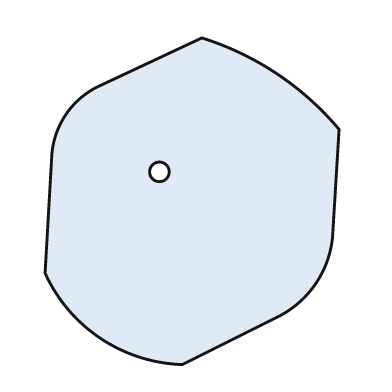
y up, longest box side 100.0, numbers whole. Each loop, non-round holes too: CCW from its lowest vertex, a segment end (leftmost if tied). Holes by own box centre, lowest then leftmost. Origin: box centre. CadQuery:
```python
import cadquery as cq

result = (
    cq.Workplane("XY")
    .moveTo(-3.0, -50.0)
    .lineTo(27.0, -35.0)
    .threePointArc((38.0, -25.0), (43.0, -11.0))
    .lineTo(45.0, 22.0)
    .threePointArc((26.0, 39.0), (3.0, 50.0))
    .lineTo(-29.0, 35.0)
    .threePointArc((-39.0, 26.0), (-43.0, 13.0))
    .lineTo(-45.0, -22.0)
    .threePointArc((-28.0, -42.0), (-3.0, -50.0))
    .close()
    .moveTo(-10.0, 9.0)
    .circle(3.0)
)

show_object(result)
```